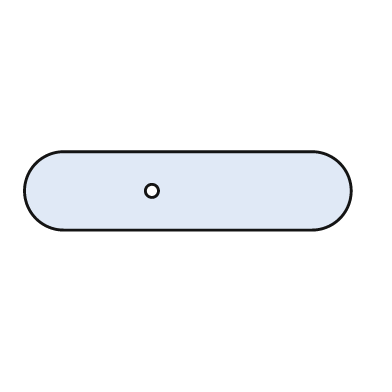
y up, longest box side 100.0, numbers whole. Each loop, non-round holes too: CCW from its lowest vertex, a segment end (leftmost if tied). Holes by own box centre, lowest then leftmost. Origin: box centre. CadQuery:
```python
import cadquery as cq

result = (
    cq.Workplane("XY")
    .moveTo(-38.0, -12.0)
    .lineTo(38.0, -12.0)
    .threePointArc((50.0, 0.0), (38.0, 12.0))
    .lineTo(-38.0, 12.0)
    .threePointArc((-50.0, 0.0), (-38.0, -12.0))
    .close()
    .moveTo(-11.0, 0.0)
    .circle(2.0)
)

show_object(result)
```